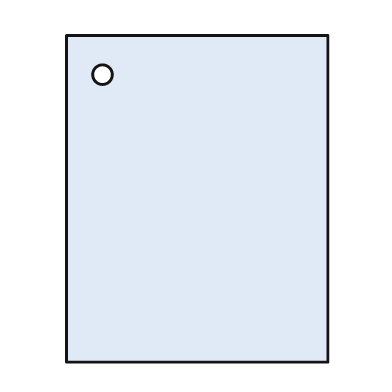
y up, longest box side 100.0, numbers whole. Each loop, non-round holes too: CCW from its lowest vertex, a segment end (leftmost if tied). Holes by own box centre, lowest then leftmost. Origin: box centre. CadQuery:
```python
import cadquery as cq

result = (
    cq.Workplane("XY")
    .moveTo(-40.0, -50.0)
    .lineTo(40.0, -50.0)
    .lineTo(40.0, 50.0)
    .lineTo(-40.0, 50.0)
    .close()
    .moveTo(-29.0, 38.0)
    .circle(3.0)
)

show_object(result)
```